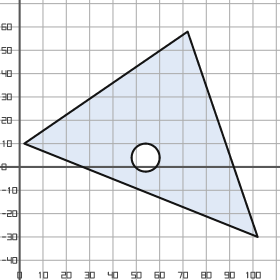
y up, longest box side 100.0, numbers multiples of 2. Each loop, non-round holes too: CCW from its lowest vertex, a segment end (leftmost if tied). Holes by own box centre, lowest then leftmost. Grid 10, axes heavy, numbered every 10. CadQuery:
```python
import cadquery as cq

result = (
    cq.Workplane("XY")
    .moveTo(102.0, -30.0)
    .lineTo(72.0, 58.0)
    .lineTo(2.0, 10.0)
    .close()
    .moveTo(54.0, 4.0)
    .circle(6.0)
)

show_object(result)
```